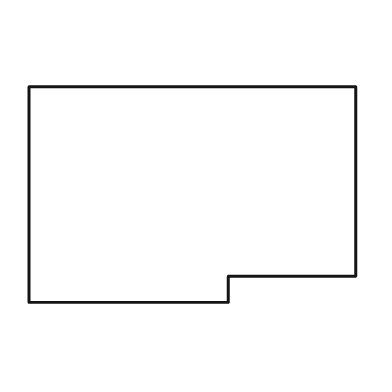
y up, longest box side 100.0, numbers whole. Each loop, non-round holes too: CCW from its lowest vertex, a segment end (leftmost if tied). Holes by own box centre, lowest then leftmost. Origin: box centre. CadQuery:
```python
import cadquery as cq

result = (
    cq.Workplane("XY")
    .moveTo(-50.0, -33.0)
    .lineTo(11.0, -33.0)
    .lineTo(11.0, -25.0)
    .lineTo(50.0, -25.0)
    .lineTo(50.0, 33.0)
    .lineTo(-50.0, 33.0)
    .close()
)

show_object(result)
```